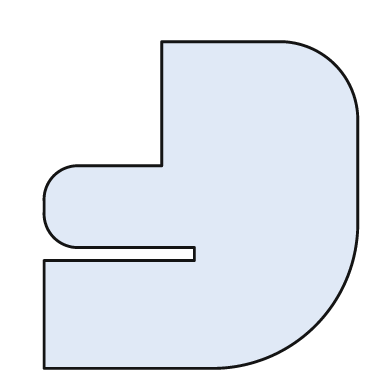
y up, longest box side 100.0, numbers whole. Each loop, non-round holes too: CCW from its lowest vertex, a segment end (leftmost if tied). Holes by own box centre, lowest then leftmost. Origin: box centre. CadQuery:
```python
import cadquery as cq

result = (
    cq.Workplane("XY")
    .moveTo(-48.0, -50.0)
    .lineTo(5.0, -50.0)
    .threePointArc((35.0, -37.0), (48.0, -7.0))
    .lineTo(48.0, 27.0)
    .threePointArc((41.0, 43.0), (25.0, 50.0))
    .lineTo(-12.0, 50.0)
    .lineTo(-12.0, 12.0)
    .lineTo(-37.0, 12.0)
    .threePointArc((-45.0, 9.0), (-48.0, 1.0))
    .lineTo(-48.0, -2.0)
    .threePointArc((-45.0, -10.0), (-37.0, -13.0))
    .lineTo(-2.0, -13.0)
    .lineTo(-2.0, -17.0)
    .lineTo(-48.0, -17.0)
    .close()
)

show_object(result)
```